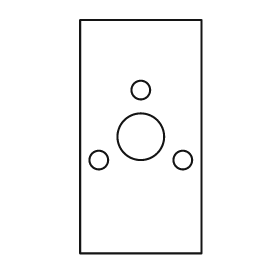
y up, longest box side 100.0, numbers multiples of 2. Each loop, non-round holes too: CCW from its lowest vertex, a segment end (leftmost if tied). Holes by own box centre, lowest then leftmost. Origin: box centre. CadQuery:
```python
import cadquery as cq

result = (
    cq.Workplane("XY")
    .moveTo(-26.0, -50.0)
    .lineTo(26.0, -50.0)
    .lineTo(26.0, 50.0)
    .lineTo(-26.0, 50.0)
    .close()
    .moveTo(-18.0, -10.0)
    .circle(4.0)
    .moveTo(18.0, -10.0)
    .circle(4.0)
    .moveTo(0.0, 0.0)
    .circle(10.0)
    .moveTo(0.0, 20.0)
    .circle(4.0)
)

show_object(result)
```